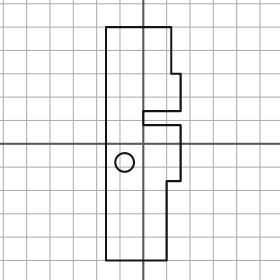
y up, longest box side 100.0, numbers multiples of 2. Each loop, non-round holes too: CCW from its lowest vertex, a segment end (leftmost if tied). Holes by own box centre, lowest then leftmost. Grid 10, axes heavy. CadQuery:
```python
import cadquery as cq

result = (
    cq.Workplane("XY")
    .moveTo(-16.0, -50.0)
    .lineTo(10.0, -50.0)
    .lineTo(10.0, -16.0)
    .lineTo(16.0, -16.0)
    .lineTo(16.0, 8.0)
    .lineTo(0.0, 8.0)
    .lineTo(0.0, 14.0)
    .lineTo(16.0, 14.0)
    .lineTo(16.0, 30.0)
    .lineTo(12.0, 30.0)
    .lineTo(12.0, 50.0)
    .lineTo(-16.0, 50.0)
    .close()
    .moveTo(-8.0, -8.0)
    .circle(4.0)
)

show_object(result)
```